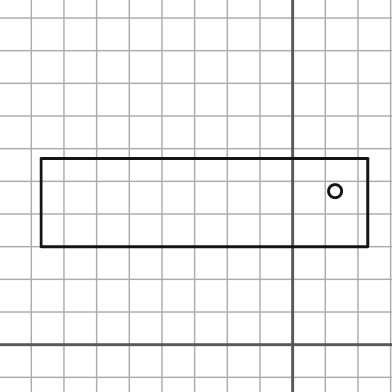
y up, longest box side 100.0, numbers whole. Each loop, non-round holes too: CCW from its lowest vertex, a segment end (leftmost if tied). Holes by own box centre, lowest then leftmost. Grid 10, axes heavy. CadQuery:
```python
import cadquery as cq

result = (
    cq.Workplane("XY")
    .moveTo(-77.0, 30.0)
    .lineTo(23.0, 30.0)
    .lineTo(23.0, 57.0)
    .lineTo(-77.0, 57.0)
    .close()
    .moveTo(13.0, 47.0)
    .circle(2.0)
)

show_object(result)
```